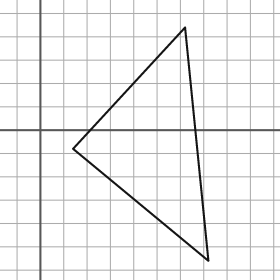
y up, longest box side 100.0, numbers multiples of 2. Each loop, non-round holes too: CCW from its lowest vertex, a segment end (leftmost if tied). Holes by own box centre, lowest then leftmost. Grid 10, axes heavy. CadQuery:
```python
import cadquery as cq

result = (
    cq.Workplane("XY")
    .moveTo(72.0, -56.0)
    .lineTo(62.0, 44.0)
    .lineTo(14.0, -8.0)
    .close()
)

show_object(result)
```